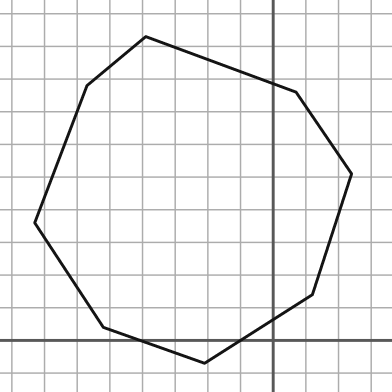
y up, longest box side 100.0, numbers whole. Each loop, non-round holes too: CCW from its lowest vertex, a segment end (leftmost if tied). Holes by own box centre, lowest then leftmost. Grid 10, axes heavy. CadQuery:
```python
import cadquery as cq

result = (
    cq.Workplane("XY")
    .moveTo(-21.0, -7.0)
    .lineTo(12.0, 14.0)
    .lineTo(24.0, 51.0)
    .lineTo(7.0, 76.0)
    .lineTo(-39.0, 93.0)
    .lineTo(-57.0, 78.0)
    .lineTo(-73.0, 36.0)
    .lineTo(-52.0, 4.0)
    .close()
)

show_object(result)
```